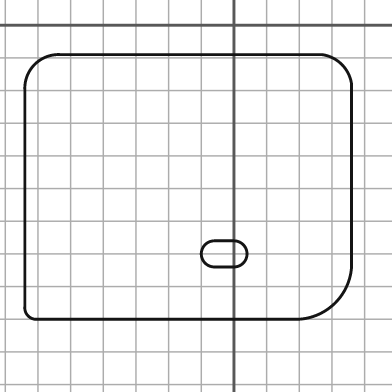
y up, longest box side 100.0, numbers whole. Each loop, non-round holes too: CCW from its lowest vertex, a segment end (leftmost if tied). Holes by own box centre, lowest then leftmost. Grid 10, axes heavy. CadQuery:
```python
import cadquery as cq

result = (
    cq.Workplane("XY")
    .moveTo(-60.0, -90.0)
    .lineTo(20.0, -90.0)
    .threePointArc((31.0, -85.0), (36.0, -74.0))
    .lineTo(36.0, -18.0)
    .threePointArc((33.0, -12.0), (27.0, -9.0))
    .lineTo(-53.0, -9.0)
    .threePointArc((-61.0, -12.0), (-64.0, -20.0))
    .lineTo(-64.0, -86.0)
    .threePointArc((-63.0, -89.0), (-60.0, -90.0))
    .close()
    .moveTo(-6.0, -74.0)
    .lineTo(0.0, -74.0)
    .threePointArc((4.0, -70.0), (0.0, -66.0))
    .lineTo(-6.0, -66.0)
    .threePointArc((-10.0, -70.0), (-6.0, -74.0))
    .close()
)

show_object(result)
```